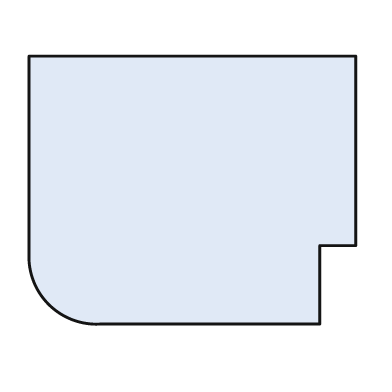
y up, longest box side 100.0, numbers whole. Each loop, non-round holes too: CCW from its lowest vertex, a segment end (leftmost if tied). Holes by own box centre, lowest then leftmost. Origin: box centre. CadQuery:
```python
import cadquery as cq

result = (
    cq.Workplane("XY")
    .moveTo(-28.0, -41.0)
    .lineTo(39.0, -41.0)
    .lineTo(39.0, -17.0)
    .lineTo(50.0, -17.0)
    .lineTo(50.0, 41.0)
    .lineTo(-50.0, 41.0)
    .lineTo(-50.0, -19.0)
    .threePointArc((-44.0, -35.0), (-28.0, -41.0))
    .close()
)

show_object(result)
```